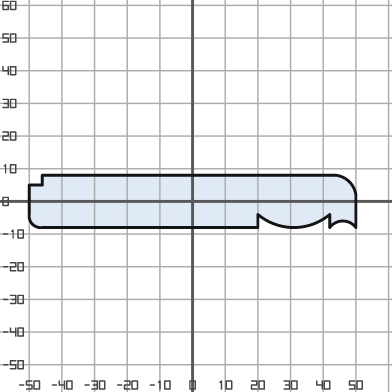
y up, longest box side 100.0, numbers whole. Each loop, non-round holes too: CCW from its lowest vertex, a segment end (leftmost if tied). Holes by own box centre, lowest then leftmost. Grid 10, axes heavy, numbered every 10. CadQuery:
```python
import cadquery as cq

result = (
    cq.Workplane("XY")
    .moveTo(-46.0, -8.0)
    .lineTo(20.0, -8.0)
    .lineTo(20.0, -4.0)
    .threePointArc((31.0, -8.0), (42.0, -4.0))
    .lineTo(42.0, -8.0)
    .threePointArc((46.0, -6.0), (50.0, -8.0))
    .lineTo(50.0, 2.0)
    .threePointArc((48.0, 6.0), (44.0, 8.0))
    .lineTo(-46.0, 8.0)
    .lineTo(-46.0, 5.0)
    .lineTo(-50.0, 5.0)
    .lineTo(-50.0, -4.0)
    .threePointArc((-49.0, -7.0), (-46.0, -8.0))
    .close()
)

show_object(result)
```